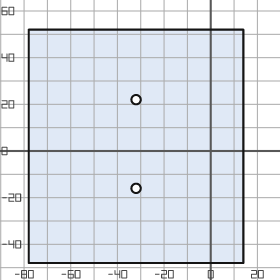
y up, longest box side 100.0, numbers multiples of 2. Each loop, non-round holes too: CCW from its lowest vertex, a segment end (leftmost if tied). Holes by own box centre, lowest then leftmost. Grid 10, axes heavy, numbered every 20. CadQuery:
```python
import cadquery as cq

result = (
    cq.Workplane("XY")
    .moveTo(-78.0, -48.0)
    .lineTo(14.0, -48.0)
    .lineTo(14.0, 52.0)
    .lineTo(-78.0, 52.0)
    .close()
    .moveTo(-32.0, -16.0)
    .circle(2.0)
    .moveTo(-32.0, 22.0)
    .circle(2.0)
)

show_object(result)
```